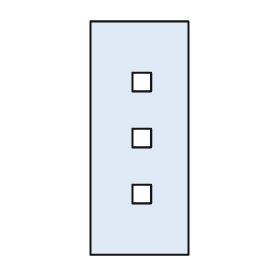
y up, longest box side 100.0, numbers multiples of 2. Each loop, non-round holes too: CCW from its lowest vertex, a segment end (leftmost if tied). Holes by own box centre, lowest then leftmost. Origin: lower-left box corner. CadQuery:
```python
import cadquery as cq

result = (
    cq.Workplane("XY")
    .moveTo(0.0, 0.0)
    .lineTo(42.0, 0.0)
    .lineTo(42.0, 100.0)
    .lineTo(0.0, 100.0)
    .close()
    .moveTo(18.0, 22.0)
    .lineTo(26.0, 22.0)
    .lineTo(26.0, 30.0)
    .lineTo(18.0, 30.0)
    .close()
    .moveTo(18.0, 46.0)
    .lineTo(26.0, 46.0)
    .lineTo(26.0, 54.0)
    .lineTo(18.0, 54.0)
    .close()
    .moveTo(18.0, 70.0)
    .lineTo(26.0, 70.0)
    .lineTo(26.0, 78.0)
    .lineTo(18.0, 78.0)
    .close()
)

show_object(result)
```